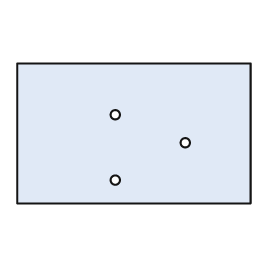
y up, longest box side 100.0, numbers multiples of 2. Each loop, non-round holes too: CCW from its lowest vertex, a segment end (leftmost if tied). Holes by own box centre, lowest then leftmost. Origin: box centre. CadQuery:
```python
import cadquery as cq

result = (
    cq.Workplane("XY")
    .moveTo(-50.0, -30.0)
    .lineTo(50.0, -30.0)
    .lineTo(50.0, 30.0)
    .lineTo(-50.0, 30.0)
    .close()
    .moveTo(-8.0, -20.0)
    .circle(2.0)
    .moveTo(22.0, -4.0)
    .circle(2.0)
    .moveTo(-8.0, 8.0)
    .circle(2.0)
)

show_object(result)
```